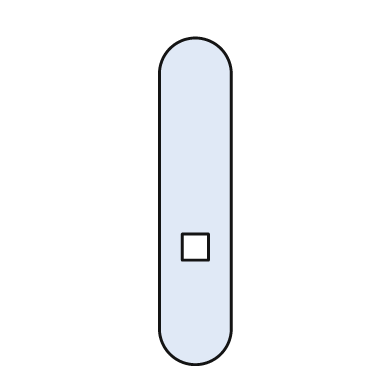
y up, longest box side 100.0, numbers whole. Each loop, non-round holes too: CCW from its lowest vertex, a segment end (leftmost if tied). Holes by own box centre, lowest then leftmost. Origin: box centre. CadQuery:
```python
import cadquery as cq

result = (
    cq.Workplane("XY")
    .moveTo(-11.0, -39.0)
    .threePointArc((0.0, -50.0), (11.0, -39.0))
    .lineTo(11.0, 39.0)
    .threePointArc((0.0, 50.0), (-11.0, 39.0))
    .close()
    .moveTo(-4.0, -18.0)
    .lineTo(4.0, -18.0)
    .lineTo(4.0, -10.0)
    .lineTo(-4.0, -10.0)
    .close()
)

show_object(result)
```